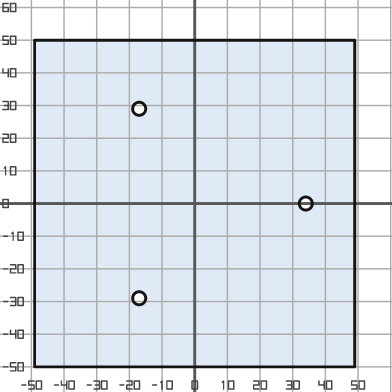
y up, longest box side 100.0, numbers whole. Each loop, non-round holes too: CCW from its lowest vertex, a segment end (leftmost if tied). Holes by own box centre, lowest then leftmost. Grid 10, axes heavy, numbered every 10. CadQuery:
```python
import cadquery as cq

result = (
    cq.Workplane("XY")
    .moveTo(-49.0, -50.0)
    .lineTo(49.0, -50.0)
    .lineTo(49.0, 50.0)
    .lineTo(-49.0, 50.0)
    .close()
    .moveTo(-17.0, -29.0)
    .circle(2.0)
    .moveTo(34.0, 0.0)
    .circle(2.0)
    .moveTo(-17.0, 29.0)
    .circle(2.0)
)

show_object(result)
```